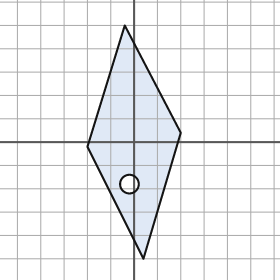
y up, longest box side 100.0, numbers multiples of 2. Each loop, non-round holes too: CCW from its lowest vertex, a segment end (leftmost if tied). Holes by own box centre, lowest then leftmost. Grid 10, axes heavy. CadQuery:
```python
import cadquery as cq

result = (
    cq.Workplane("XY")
    .moveTo(4.0, -50.0)
    .lineTo(20.0, 4.0)
    .lineTo(-4.0, 50.0)
    .lineTo(-20.0, -2.0)
    .close()
    .moveTo(-2.0, -18.0)
    .circle(4.0)
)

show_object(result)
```